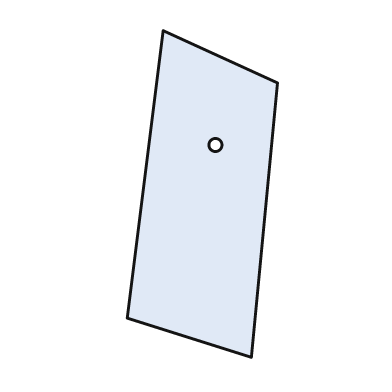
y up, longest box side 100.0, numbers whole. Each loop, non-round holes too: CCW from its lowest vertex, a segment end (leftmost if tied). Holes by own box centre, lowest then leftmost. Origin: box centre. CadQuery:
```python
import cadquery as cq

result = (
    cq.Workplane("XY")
    .moveTo(15.0, -50.0)
    .lineTo(23.0, 34.0)
    .lineTo(-12.0, 50.0)
    .lineTo(-23.0, -38.0)
    .close()
    .moveTo(4.0, 15.0)
    .circle(2.0)
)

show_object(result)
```